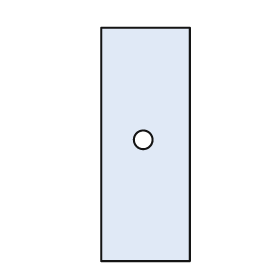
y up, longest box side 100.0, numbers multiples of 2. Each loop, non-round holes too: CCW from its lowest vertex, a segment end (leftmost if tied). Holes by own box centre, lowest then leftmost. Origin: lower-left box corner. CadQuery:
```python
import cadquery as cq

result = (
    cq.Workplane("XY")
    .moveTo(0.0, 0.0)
    .lineTo(38.0, 0.0)
    .lineTo(38.0, 100.0)
    .lineTo(0.0, 100.0)
    .close()
    .moveTo(18.0, 52.0)
    .circle(4.0)
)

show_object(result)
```